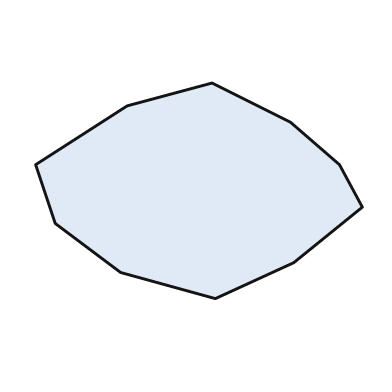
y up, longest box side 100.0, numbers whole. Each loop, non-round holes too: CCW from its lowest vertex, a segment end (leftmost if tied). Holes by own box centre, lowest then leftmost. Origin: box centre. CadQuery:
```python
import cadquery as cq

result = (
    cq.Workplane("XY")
    .moveTo(5.0, -33.0)
    .lineTo(29.0, -22.0)
    .lineTo(50.0, -5.0)
    .lineTo(43.0, 8.0)
    .lineTo(28.0, 21.0)
    .lineTo(4.0, 33.0)
    .lineTo(-22.0, 26.0)
    .lineTo(-50.0, 8.0)
    .lineTo(-44.0, -10.0)
    .lineTo(-24.0, -25.0)
    .close()
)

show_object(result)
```